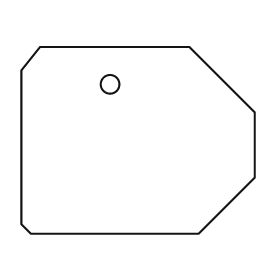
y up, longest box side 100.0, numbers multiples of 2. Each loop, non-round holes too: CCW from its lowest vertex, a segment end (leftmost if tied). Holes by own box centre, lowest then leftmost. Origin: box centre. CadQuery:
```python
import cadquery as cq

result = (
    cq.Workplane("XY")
    .moveTo(-46.0, -40.0)
    .lineTo(26.0, -40.0)
    .lineTo(50.0, -16.0)
    .lineTo(50.0, 12.0)
    .lineTo(22.0, 40.0)
    .lineTo(-42.0, 40.0)
    .lineTo(-50.0, 30.0)
    .lineTo(-50.0, -36.0)
    .close()
    .moveTo(-12.0, 24.0)
    .circle(4.0)
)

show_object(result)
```